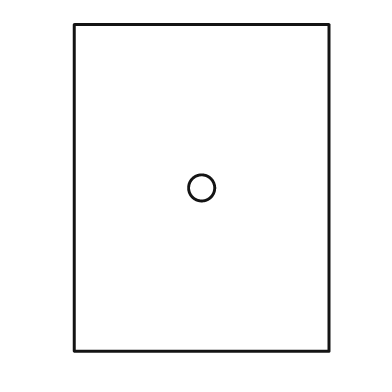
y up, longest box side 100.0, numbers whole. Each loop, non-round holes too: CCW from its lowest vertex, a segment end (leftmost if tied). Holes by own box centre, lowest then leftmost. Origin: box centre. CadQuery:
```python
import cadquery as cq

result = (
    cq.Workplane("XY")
    .moveTo(-39.0, -50.0)
    .lineTo(39.0, -50.0)
    .lineTo(39.0, 50.0)
    .lineTo(-39.0, 50.0)
    .close()
    .moveTo(0.0, 0.0)
    .circle(4.0)
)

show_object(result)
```